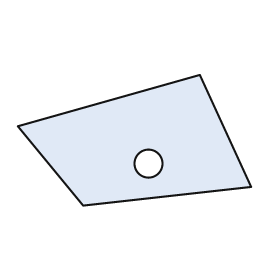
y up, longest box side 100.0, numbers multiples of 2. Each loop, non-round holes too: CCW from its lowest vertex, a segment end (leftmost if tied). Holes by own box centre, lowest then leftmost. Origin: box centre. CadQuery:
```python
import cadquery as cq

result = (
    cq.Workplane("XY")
    .moveTo(-22.0, -28.0)
    .lineTo(50.0, -20.0)
    .lineTo(28.0, 28.0)
    .lineTo(-50.0, 6.0)
    .close()
    .moveTo(6.0, -10.0)
    .circle(6.0)
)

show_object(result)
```